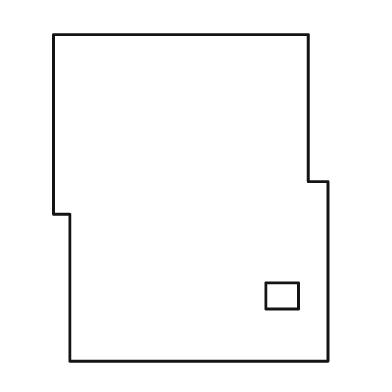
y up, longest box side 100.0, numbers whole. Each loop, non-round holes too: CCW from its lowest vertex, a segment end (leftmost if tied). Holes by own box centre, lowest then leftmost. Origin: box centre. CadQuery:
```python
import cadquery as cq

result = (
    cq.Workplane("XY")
    .moveTo(-37.0, -50.0)
    .lineTo(42.0, -50.0)
    .lineTo(42.0, 5.0)
    .lineTo(36.0, 5.0)
    .lineTo(36.0, 50.0)
    .lineTo(-42.0, 50.0)
    .lineTo(-42.0, -5.0)
    .lineTo(-37.0, -5.0)
    .close()
    .moveTo(23.0, -34.0)
    .lineTo(33.0, -34.0)
    .lineTo(33.0, -26.0)
    .lineTo(23.0, -26.0)
    .close()
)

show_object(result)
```